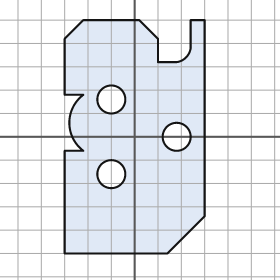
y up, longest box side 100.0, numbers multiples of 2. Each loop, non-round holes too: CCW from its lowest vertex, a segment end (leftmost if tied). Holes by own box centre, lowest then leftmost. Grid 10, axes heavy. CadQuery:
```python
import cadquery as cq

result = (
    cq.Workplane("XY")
    .moveTo(-30.0, -50.0)
    .lineTo(14.0, -50.0)
    .lineTo(30.0, -34.0)
    .lineTo(30.0, 50.0)
    .lineTo(24.0, 50.0)
    .lineTo(24.0, 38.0)
    .threePointArc((22.0, 34.0), (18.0, 32.0))
    .lineTo(10.0, 32.0)
    .lineTo(10.0, 42.0)
    .lineTo(2.0, 50.0)
    .lineTo(-22.0, 50.0)
    .lineTo(-30.0, 42.0)
    .lineTo(-30.0, 18.0)
    .lineTo(-22.0, 18.0)
    .threePointArc((-28.0, 6.0), (-22.0, -6.0))
    .lineTo(-30.0, -6.0)
    .close()
    .moveTo(-10.0, -16.0)
    .circle(6.0)
    .moveTo(18.0, 0.0)
    .circle(6.0)
    .moveTo(-10.0, 16.0)
    .circle(6.0)
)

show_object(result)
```